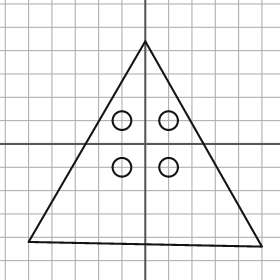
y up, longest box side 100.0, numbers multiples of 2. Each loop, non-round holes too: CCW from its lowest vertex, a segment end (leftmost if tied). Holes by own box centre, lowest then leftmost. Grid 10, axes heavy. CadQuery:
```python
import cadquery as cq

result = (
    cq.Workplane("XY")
    .moveTo(50.0, -44.0)
    .lineTo(0.0, 44.0)
    .lineTo(-50.0, -42.0)
    .close()
    .moveTo(-10.0, -10.0)
    .circle(4.0)
    .moveTo(10.0, -10.0)
    .circle(4.0)
    .moveTo(-10.0, 10.0)
    .circle(4.0)
    .moveTo(10.0, 10.0)
    .circle(4.0)
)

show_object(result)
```